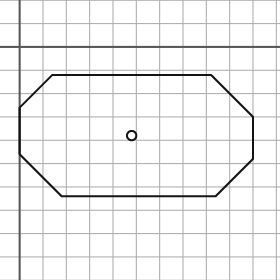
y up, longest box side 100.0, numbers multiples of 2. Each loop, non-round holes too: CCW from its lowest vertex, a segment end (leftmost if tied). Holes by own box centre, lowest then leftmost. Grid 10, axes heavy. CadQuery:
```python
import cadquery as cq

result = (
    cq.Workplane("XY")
    .moveTo(18.0, -64.0)
    .lineTo(84.0, -64.0)
    .lineTo(100.0, -48.0)
    .lineTo(100.0, -30.0)
    .lineTo(82.0, -12.0)
    .lineTo(14.0, -12.0)
    .lineTo(0.0, -26.0)
    .lineTo(0.0, -46.0)
    .close()
    .moveTo(48.0, -38.0)
    .circle(2.0)
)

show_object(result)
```